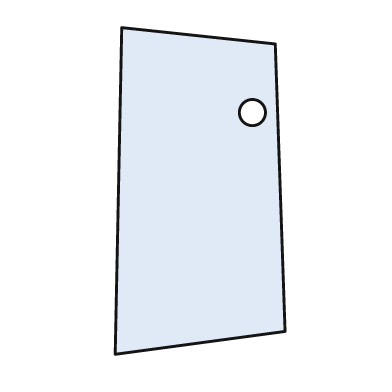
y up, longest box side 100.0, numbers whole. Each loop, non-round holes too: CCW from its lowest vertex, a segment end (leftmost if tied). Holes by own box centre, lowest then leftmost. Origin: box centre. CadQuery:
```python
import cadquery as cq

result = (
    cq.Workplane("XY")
    .moveTo(-26.0, -50.0)
    .lineTo(26.0, -43.0)
    .lineTo(23.0, 45.0)
    .lineTo(-24.0, 50.0)
    .close()
    .moveTo(16.0, 24.0)
    .circle(4.0)
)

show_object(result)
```